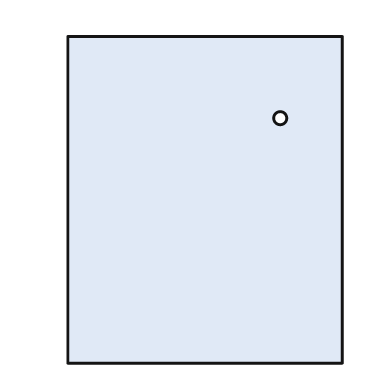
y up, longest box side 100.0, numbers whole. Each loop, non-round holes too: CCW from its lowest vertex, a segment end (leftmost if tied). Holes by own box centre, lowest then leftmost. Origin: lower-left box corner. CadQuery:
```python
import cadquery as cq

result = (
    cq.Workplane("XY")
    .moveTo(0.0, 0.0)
    .lineTo(84.0, 0.0)
    .lineTo(84.0, 100.0)
    .lineTo(0.0, 100.0)
    .close()
    .moveTo(65.0, 75.0)
    .circle(2.0)
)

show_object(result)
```